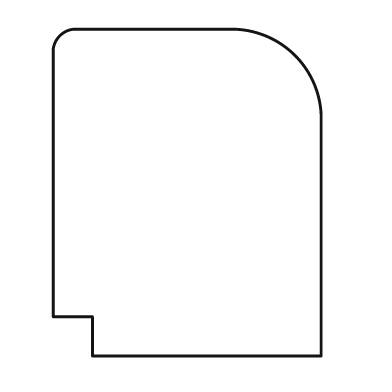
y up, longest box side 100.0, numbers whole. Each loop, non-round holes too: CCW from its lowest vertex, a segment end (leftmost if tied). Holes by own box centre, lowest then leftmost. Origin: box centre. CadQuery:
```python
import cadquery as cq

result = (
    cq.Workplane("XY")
    .moveTo(-29.0, -50.0)
    .lineTo(41.0, -50.0)
    .lineTo(41.0, 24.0)
    .threePointArc((33.0, 42.0), (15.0, 50.0))
    .lineTo(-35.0, 50.0)
    .threePointArc((-39.0, 48.0), (-41.0, 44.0))
    .lineTo(-41.0, -38.0)
    .lineTo(-29.0, -38.0)
    .close()
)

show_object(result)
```